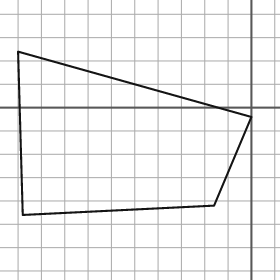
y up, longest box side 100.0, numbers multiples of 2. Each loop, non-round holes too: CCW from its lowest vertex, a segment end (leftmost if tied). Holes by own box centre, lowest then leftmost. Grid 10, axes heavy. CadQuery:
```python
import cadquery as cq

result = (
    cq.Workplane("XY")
    .moveTo(-98.0, -46.0)
    .lineTo(-16.0, -42.0)
    .lineTo(0.0, -4.0)
    .lineTo(-100.0, 24.0)
    .close()
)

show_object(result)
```